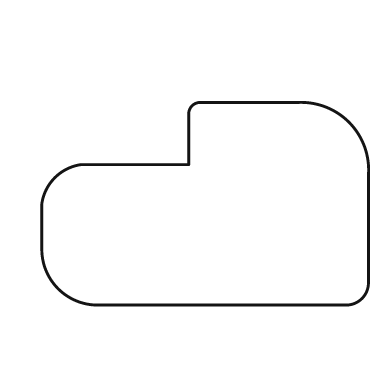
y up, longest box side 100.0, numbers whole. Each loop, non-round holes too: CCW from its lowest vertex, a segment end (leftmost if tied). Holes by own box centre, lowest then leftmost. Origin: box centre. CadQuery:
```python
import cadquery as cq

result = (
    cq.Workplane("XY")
    .moveTo(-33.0, -31.0)
    .lineTo(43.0, -31.0)
    .threePointArc((48.0, -29.0), (50.0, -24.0))
    .lineTo(50.0, 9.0)
    .threePointArc((44.0, 25.0), (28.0, 31.0))
    .lineTo(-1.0, 31.0)
    .threePointArc((-4.0, 30.0), (-5.0, 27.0))
    .lineTo(-5.0, 12.0)
    .lineTo(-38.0, 12.0)
    .threePointArc((-46.0, 8.0), (-50.0, 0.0))
    .lineTo(-50.0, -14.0)
    .threePointArc((-45.0, -26.0), (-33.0, -31.0))
    .close()
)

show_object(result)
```